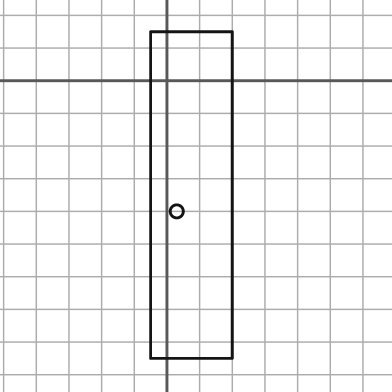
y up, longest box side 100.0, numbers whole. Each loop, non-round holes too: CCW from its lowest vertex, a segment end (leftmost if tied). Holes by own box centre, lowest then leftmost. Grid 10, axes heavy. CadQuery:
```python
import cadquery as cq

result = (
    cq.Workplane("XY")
    .moveTo(-5.0, -85.0)
    .lineTo(20.0, -85.0)
    .lineTo(20.0, 15.0)
    .lineTo(-5.0, 15.0)
    .close()
    .moveTo(3.0, -40.0)
    .circle(2.0)
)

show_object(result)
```